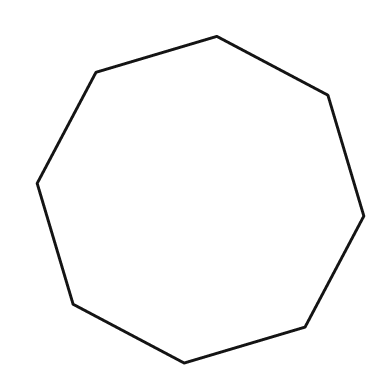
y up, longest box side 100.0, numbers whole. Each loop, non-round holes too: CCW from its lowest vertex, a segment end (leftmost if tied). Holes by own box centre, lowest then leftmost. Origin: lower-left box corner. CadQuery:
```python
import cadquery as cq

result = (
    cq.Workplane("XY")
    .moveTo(45.0, 0.0)
    .lineTo(82.0, 11.0)
    .lineTo(100.0, 45.0)
    .lineTo(89.0, 82.0)
    .lineTo(55.0, 100.0)
    .lineTo(18.0, 89.0)
    .lineTo(0.0, 55.0)
    .lineTo(11.0, 18.0)
    .close()
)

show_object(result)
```